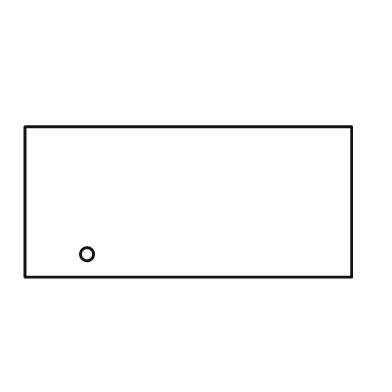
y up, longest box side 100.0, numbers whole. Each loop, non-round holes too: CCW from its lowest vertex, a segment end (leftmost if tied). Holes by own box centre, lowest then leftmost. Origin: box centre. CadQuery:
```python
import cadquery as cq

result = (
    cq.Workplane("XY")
    .moveTo(-50.0, -23.0)
    .lineTo(50.0, -23.0)
    .lineTo(50.0, 23.0)
    .lineTo(-50.0, 23.0)
    .close()
    .moveTo(-31.0, -16.0)
    .circle(2.0)
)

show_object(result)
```